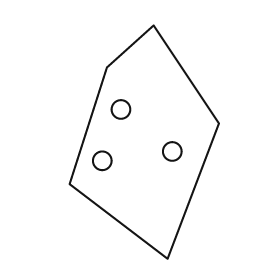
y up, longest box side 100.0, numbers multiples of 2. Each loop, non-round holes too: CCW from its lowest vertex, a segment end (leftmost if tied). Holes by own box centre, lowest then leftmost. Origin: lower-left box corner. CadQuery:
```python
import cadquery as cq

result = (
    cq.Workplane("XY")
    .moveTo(42.0, 0.0)
    .lineTo(64.0, 58.0)
    .lineTo(36.0, 100.0)
    .lineTo(16.0, 82.0)
    .lineTo(0.0, 32.0)
    .close()
    .moveTo(14.0, 42.0)
    .circle(4.0)
    .moveTo(44.0, 46.0)
    .circle(4.0)
    .moveTo(22.0, 64.0)
    .circle(4.0)
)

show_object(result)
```